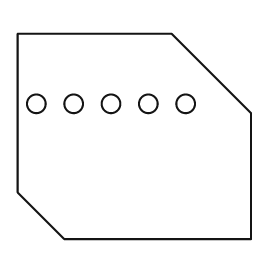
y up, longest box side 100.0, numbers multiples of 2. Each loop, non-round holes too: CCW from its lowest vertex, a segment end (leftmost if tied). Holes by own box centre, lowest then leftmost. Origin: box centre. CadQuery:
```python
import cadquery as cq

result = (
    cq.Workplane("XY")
    .moveTo(-30.0, -44.0)
    .lineTo(50.0, -44.0)
    .lineTo(50.0, 10.0)
    .lineTo(16.0, 44.0)
    .lineTo(-50.0, 44.0)
    .lineTo(-50.0, -24.0)
    .close()
    .moveTo(-42.0, 14.0)
    .circle(4.0)
    .moveTo(-26.0, 14.0)
    .circle(4.0)
    .moveTo(-10.0, 14.0)
    .circle(4.0)
    .moveTo(6.0, 14.0)
    .circle(4.0)
    .moveTo(22.0, 14.0)
    .circle(4.0)
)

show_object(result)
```